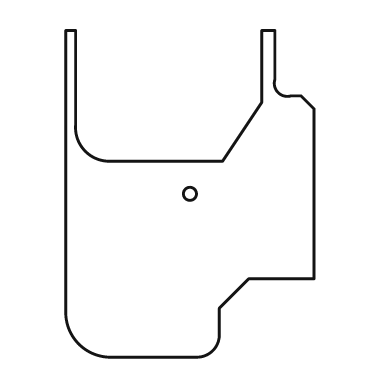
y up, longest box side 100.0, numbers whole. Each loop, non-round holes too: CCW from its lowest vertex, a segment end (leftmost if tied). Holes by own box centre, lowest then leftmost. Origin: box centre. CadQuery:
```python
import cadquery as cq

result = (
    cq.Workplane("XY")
    .moveTo(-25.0, -50.0)
    .lineTo(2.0, -50.0)
    .threePointArc((7.0, -48.0), (9.0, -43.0))
    .lineTo(9.0, -35.0)
    .lineTo(18.0, -26.0)
    .lineTo(38.0, -26.0)
    .lineTo(38.0, 26.0)
    .lineTo(34.0, 30.0)
    .lineTo(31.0, 30.0)
    .threePointArc((27.0, 31.0), (26.0, 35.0))
    .lineTo(26.0, 50.0)
    .lineTo(22.0, 50.0)
    .lineTo(22.0, 28.0)
    .lineTo(10.0, 10.0)
    .lineTo(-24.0, 10.0)
    .threePointArc((-32.0, 13.0), (-35.0, 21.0))
    .lineTo(-35.0, 50.0)
    .lineTo(-38.0, 50.0)
    .lineTo(-38.0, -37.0)
    .threePointArc((-34.0, -46.0), (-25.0, -50.0))
    .close()
    .moveTo(0.0, 0.0)
    .circle(2.0)
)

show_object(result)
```